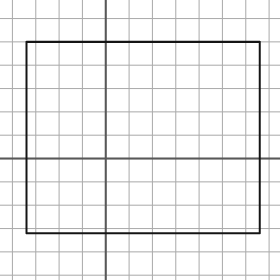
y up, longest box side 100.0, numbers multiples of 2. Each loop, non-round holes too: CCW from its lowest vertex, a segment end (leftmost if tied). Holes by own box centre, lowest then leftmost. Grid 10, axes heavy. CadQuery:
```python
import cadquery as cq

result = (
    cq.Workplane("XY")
    .moveTo(-34.0, -32.0)
    .lineTo(66.0, -32.0)
    .lineTo(66.0, 50.0)
    .lineTo(-34.0, 50.0)
    .close()
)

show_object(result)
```